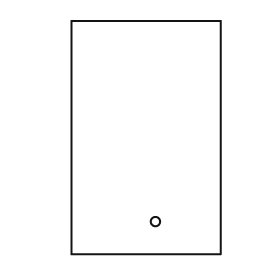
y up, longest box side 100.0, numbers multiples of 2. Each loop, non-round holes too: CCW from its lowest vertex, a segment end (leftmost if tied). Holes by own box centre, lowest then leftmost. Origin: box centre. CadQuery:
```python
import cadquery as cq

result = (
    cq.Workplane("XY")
    .moveTo(-32.0, -50.0)
    .lineTo(32.0, -50.0)
    .lineTo(32.0, 50.0)
    .lineTo(-32.0, 50.0)
    .close()
    .moveTo(4.0, -36.0)
    .circle(2.0)
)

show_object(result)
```